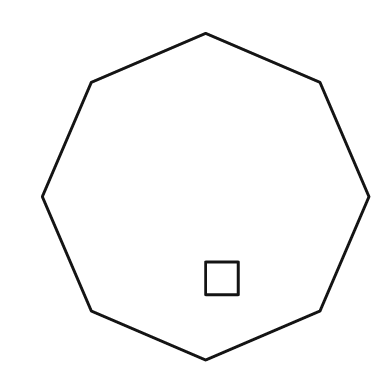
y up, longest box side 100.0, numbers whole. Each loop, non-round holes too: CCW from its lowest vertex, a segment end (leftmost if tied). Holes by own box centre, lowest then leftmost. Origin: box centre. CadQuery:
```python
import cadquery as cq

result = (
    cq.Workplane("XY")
    .moveTo(0.0, -50.0)
    .lineTo(35.0, -35.0)
    .lineTo(50.0, 0.0)
    .lineTo(35.0, 35.0)
    .lineTo(0.0, 50.0)
    .lineTo(-35.0, 35.0)
    .lineTo(-50.0, 0.0)
    .lineTo(-35.0, -35.0)
    .close()
    .moveTo(0.0, -30.0)
    .lineTo(10.0, -30.0)
    .lineTo(10.0, -20.0)
    .lineTo(0.0, -20.0)
    .close()
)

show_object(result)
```